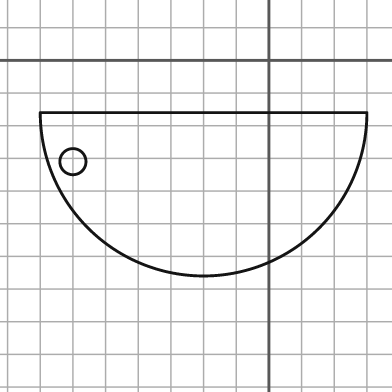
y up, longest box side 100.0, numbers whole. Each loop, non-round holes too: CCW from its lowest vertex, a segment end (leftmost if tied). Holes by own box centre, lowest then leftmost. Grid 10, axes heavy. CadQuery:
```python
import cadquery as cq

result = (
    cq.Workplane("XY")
    .moveTo(-70.0, -16.0)
    .threePointArc((-20.0, -66.0), (30.0, -16.0))
    .close()
    .moveTo(-60.0, -31.0)
    .circle(4.0)
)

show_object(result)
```